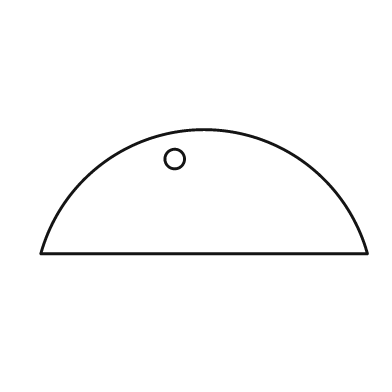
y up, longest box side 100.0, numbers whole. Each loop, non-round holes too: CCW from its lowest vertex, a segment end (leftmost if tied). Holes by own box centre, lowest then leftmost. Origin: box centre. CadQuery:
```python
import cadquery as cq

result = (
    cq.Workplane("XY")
    .moveTo(-50.0, -19.0)
    .lineTo(50.0, -19.0)
    .threePointArc((0.0, 19.0), (-50.0, -19.0))
    .close()
    .moveTo(-9.0, 10.0)
    .circle(3.0)
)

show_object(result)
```